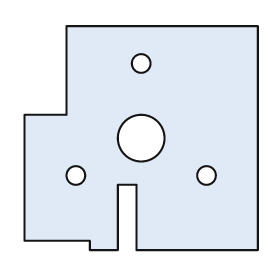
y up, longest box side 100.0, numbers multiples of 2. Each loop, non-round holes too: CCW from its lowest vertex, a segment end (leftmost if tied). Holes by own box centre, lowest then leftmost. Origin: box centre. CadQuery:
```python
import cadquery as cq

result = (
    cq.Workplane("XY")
    .moveTo(-22.0, -48.0)
    .lineTo(-10.0, -48.0)
    .lineTo(-10.0, -20.0)
    .lineTo(-2.0, -20.0)
    .lineTo(-2.0, -48.0)
    .lineTo(50.0, -48.0)
    .lineTo(50.0, 48.0)
    .lineTo(-32.0, 48.0)
    .lineTo(-32.0, 10.0)
    .lineTo(-50.0, 10.0)
    .lineTo(-50.0, -44.0)
    .lineTo(-22.0, -44.0)
    .close()
    .moveTo(-28.0, -16.0)
    .circle(4.0)
    .moveTo(28.0, -16.0)
    .circle(4.0)
    .moveTo(0.0, 0.0)
    .circle(10.0)
    .moveTo(0.0, 32.0)
    .circle(4.0)
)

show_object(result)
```